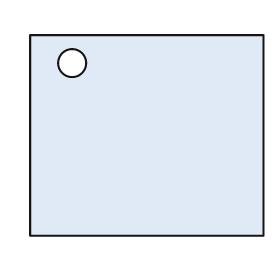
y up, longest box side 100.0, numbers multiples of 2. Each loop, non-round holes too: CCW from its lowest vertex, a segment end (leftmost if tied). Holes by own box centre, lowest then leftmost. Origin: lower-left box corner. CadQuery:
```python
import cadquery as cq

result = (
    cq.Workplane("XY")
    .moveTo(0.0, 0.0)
    .lineTo(100.0, 0.0)
    .lineTo(100.0, 86.0)
    .lineTo(0.0, 86.0)
    .close()
    .moveTo(18.0, 74.0)
    .circle(6.0)
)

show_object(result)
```